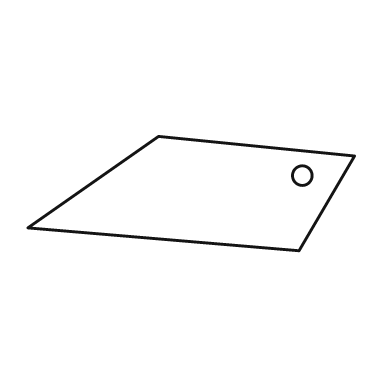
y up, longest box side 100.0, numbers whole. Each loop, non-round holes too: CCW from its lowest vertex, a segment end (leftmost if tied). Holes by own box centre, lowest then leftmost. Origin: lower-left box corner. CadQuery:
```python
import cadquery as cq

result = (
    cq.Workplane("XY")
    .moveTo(83.0, 0.0)
    .lineTo(100.0, 29.0)
    .lineTo(40.0, 35.0)
    .lineTo(0.0, 7.0)
    .close()
    .moveTo(84.0, 23.0)
    .circle(3.0)
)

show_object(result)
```